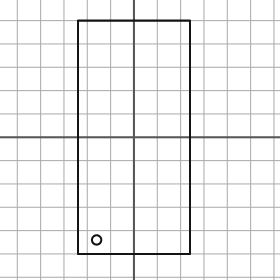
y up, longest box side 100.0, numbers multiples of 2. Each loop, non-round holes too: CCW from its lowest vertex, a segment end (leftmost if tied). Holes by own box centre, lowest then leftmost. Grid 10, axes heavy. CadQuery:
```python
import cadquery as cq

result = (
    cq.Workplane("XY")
    .moveTo(-24.0, -50.0)
    .lineTo(24.0, -50.0)
    .lineTo(24.0, 50.0)
    .lineTo(-24.0, 50.0)
    .close()
    .moveTo(-16.0, -44.0)
    .circle(2.0)
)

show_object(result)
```